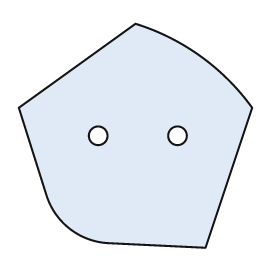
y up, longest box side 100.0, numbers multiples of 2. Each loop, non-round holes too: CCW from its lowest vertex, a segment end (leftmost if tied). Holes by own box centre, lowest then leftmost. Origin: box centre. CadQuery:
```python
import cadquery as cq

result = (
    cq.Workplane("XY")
    .moveTo(30.0, -48.0)
    .lineTo(50.0, 12.0)
    .threePointArc((28.0, 34.0), (0.0, 48.0))
    .lineTo(-50.0, 12.0)
    .lineTo(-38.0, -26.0)
    .threePointArc((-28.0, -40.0), (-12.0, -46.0))
    .close()
    .moveTo(-16.0, 0.0)
    .circle(4.0)
    .moveTo(18.0, 0.0)
    .circle(4.0)
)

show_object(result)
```